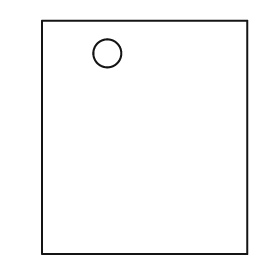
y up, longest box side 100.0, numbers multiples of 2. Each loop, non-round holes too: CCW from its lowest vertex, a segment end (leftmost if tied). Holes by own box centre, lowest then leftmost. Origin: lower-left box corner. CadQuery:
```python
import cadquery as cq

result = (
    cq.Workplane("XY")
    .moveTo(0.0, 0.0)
    .lineTo(88.0, 0.0)
    .lineTo(88.0, 100.0)
    .lineTo(0.0, 100.0)
    .close()
    .moveTo(28.0, 86.0)
    .circle(6.0)
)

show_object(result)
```